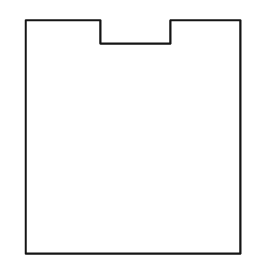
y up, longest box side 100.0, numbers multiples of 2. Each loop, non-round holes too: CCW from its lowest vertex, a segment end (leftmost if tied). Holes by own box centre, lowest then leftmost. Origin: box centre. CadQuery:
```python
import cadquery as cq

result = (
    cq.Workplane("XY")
    .moveTo(-46.0, -50.0)
    .lineTo(46.0, -50.0)
    .lineTo(46.0, 50.0)
    .lineTo(16.0, 50.0)
    .lineTo(16.0, 40.0)
    .lineTo(-14.0, 40.0)
    .lineTo(-14.0, 50.0)
    .lineTo(-46.0, 50.0)
    .close()
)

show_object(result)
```